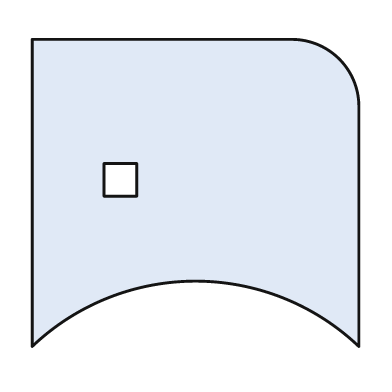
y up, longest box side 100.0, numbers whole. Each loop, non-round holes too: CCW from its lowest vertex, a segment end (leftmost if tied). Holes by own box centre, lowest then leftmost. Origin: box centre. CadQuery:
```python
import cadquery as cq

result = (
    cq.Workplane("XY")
    .moveTo(-50.0, -47.0)
    .threePointArc((0.0, -27.0), (50.0, -47.0))
    .lineTo(50.0, 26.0)
    .threePointArc((44.0, 41.0), (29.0, 47.0))
    .lineTo(-50.0, 47.0)
    .close()
    .moveTo(-28.0, -1.0)
    .lineTo(-18.0, -1.0)
    .lineTo(-18.0, 9.0)
    .lineTo(-28.0, 9.0)
    .close()
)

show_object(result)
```